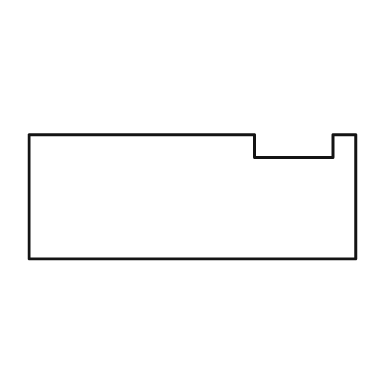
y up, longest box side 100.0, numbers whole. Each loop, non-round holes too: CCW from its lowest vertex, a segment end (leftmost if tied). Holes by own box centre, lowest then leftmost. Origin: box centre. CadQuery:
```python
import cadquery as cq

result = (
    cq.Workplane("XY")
    .moveTo(-50.0, -19.0)
    .lineTo(50.0, -19.0)
    .lineTo(50.0, 19.0)
    .lineTo(43.0, 19.0)
    .lineTo(43.0, 12.0)
    .lineTo(19.0, 12.0)
    .lineTo(19.0, 19.0)
    .lineTo(-50.0, 19.0)
    .close()
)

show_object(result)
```